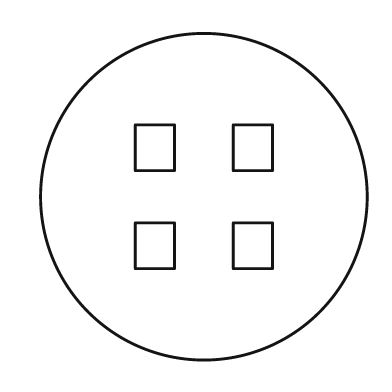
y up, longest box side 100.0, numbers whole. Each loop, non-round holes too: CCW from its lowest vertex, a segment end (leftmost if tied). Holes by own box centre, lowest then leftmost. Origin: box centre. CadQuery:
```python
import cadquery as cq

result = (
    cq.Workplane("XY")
    .moveTo(0.0, 0.0)
    .circle(50.0)
    .moveTo(-21.0, -22.0)
    .lineTo(-9.0, -22.0)
    .lineTo(-9.0, -8.0)
    .lineTo(-21.0, -8.0)
    .close()
    .moveTo(9.0, -22.0)
    .lineTo(21.0, -22.0)
    .lineTo(21.0, -8.0)
    .lineTo(9.0, -8.0)
    .close()
    .moveTo(-21.0, 8.0)
    .lineTo(-9.0, 8.0)
    .lineTo(-9.0, 22.0)
    .lineTo(-21.0, 22.0)
    .close()
    .moveTo(9.0, 8.0)
    .lineTo(21.0, 8.0)
    .lineTo(21.0, 22.0)
    .lineTo(9.0, 22.0)
    .close()
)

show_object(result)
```